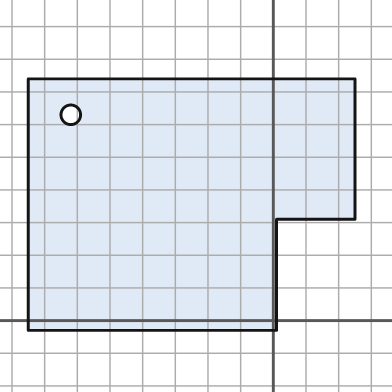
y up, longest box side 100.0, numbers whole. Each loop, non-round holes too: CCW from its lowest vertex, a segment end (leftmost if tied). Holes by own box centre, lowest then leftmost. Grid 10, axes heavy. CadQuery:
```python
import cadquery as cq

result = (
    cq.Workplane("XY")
    .moveTo(-75.0, -3.0)
    .lineTo(1.0, -3.0)
    .lineTo(1.0, 31.0)
    .lineTo(25.0, 31.0)
    .lineTo(25.0, 74.0)
    .lineTo(-75.0, 74.0)
    .close()
    .moveTo(-62.0, 63.0)
    .circle(3.0)
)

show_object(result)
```